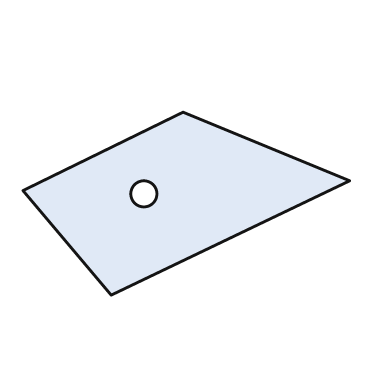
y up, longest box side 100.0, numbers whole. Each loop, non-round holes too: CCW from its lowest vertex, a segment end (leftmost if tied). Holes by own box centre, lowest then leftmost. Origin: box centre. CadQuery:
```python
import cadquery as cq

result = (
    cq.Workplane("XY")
    .moveTo(-23.0, -28.0)
    .lineTo(50.0, 7.0)
    .lineTo(-1.0, 28.0)
    .lineTo(-50.0, 4.0)
    .close()
    .moveTo(-13.0, 3.0)
    .circle(4.0)
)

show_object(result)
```